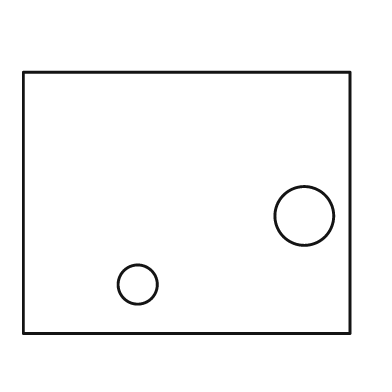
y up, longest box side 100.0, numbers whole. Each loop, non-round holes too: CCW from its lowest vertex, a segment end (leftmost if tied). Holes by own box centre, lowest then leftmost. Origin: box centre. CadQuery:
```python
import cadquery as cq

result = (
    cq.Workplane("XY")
    .moveTo(-50.0, -40.0)
    .lineTo(50.0, -40.0)
    .lineTo(50.0, 40.0)
    .lineTo(-50.0, 40.0)
    .close()
    .moveTo(-15.0, -25.0)
    .circle(6.0)
    .moveTo(36.0, -4.0)
    .circle(9.0)
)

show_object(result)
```